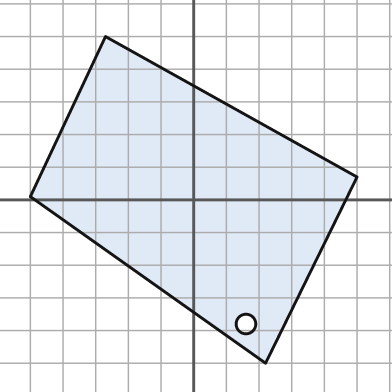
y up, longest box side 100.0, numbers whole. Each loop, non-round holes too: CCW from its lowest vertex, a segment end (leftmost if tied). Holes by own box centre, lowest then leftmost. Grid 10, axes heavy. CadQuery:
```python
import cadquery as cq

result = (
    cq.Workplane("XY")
    .moveTo(22.0, -50.0)
    .lineTo(50.0, 7.0)
    .lineTo(-27.0, 50.0)
    .lineTo(-50.0, 1.0)
    .close()
    .moveTo(16.0, -38.0)
    .circle(3.0)
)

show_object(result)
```